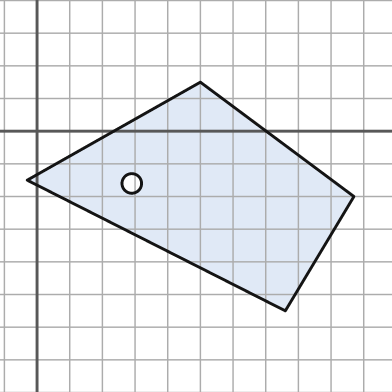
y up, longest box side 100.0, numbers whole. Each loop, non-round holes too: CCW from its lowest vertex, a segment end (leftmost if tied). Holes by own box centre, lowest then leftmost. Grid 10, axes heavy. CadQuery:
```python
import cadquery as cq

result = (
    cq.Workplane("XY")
    .moveTo(76.0, -55.0)
    .lineTo(97.0, -20.0)
    .lineTo(50.0, 15.0)
    .lineTo(-3.0, -15.0)
    .close()
    .moveTo(29.0, -16.0)
    .circle(3.0)
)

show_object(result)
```